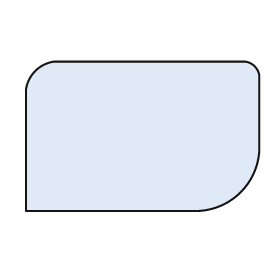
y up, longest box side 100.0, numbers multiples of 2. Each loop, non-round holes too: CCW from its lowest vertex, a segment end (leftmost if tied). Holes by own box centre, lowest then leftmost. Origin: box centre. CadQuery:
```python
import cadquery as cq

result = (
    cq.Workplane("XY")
    .moveTo(-50.0, -32.0)
    .lineTo(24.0, -32.0)
    .threePointArc((42.0, -24.0), (50.0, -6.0))
    .lineTo(50.0, 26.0)
    .threePointArc((48.0, 30.0), (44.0, 32.0))
    .lineTo(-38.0, 32.0)
    .threePointArc((-46.0, 28.0), (-50.0, 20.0))
    .close()
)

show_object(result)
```